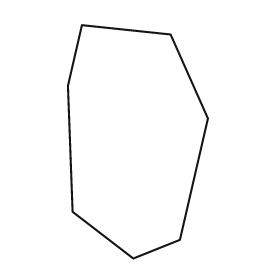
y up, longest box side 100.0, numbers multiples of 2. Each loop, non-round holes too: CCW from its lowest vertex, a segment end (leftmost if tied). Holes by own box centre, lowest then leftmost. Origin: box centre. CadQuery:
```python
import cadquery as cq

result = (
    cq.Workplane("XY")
    .moveTo(-2.0, -50.0)
    .lineTo(18.0, -42.0)
    .lineTo(30.0, 10.0)
    .lineTo(14.0, 46.0)
    .lineTo(-24.0, 50.0)
    .lineTo(-30.0, 24.0)
    .lineTo(-28.0, -30.0)
    .close()
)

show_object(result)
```